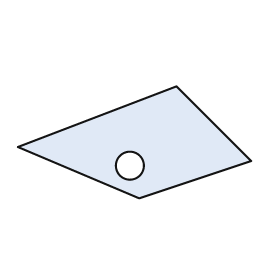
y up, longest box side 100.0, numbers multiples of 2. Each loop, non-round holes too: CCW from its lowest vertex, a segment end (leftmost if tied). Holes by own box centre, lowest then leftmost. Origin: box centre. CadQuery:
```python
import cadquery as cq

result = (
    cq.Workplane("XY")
    .moveTo(2.0, -24.0)
    .lineTo(50.0, -8.0)
    .lineTo(18.0, 24.0)
    .lineTo(-50.0, -2.0)
    .close()
    .moveTo(-2.0, -10.0)
    .circle(6.0)
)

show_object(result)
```